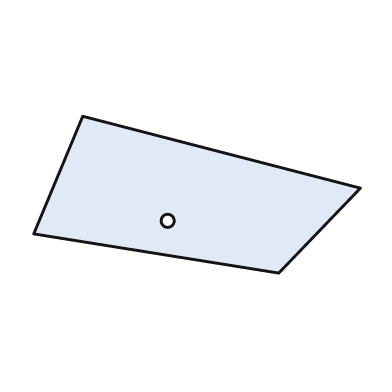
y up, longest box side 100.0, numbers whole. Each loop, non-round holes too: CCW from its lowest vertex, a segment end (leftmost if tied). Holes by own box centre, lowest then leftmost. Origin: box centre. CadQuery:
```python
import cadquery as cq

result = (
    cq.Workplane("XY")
    .moveTo(25.0, -24.0)
    .lineTo(50.0, 2.0)
    .lineTo(-35.0, 24.0)
    .lineTo(-50.0, -12.0)
    .close()
    .moveTo(-9.0, -8.0)
    .circle(2.0)
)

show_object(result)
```